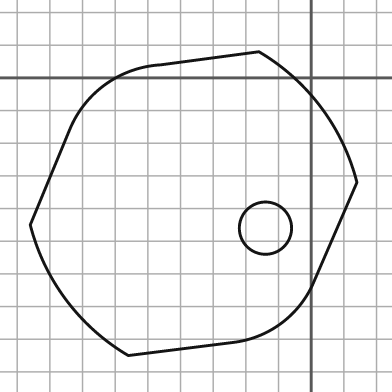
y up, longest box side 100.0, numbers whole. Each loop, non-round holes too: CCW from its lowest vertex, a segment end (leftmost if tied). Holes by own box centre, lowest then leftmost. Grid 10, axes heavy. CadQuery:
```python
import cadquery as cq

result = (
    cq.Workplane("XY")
    .moveTo(-56.0, -85.0)
    .lineTo(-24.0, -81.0)
    .threePointArc((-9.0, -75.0), (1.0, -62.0))
    .lineTo(14.0, -32.0)
    .threePointArc((3.0, -9.0), (-16.0, 8.0))
    .lineTo(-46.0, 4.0)
    .threePointArc((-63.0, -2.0), (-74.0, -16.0))
    .lineTo(-86.0, -45.0)
    .threePointArc((-75.0, -68.0), (-56.0, -85.0))
    .close()
    .moveTo(-14.0, -46.0)
    .circle(8.0)
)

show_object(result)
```